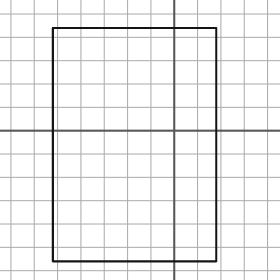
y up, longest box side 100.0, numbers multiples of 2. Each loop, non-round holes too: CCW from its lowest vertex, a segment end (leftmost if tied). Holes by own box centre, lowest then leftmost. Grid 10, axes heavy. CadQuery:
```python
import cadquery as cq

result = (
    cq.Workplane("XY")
    .moveTo(-52.0, -56.0)
    .lineTo(18.0, -56.0)
    .lineTo(18.0, 44.0)
    .lineTo(-52.0, 44.0)
    .close()
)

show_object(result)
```